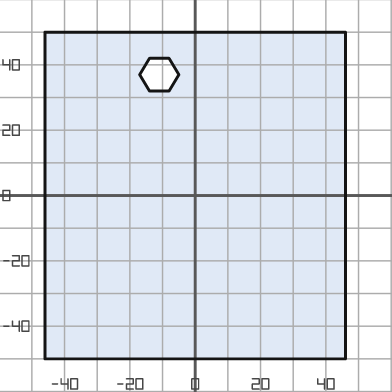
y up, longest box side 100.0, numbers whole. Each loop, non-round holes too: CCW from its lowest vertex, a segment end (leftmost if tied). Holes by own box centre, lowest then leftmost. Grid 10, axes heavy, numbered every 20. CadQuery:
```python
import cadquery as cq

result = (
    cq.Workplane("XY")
    .moveTo(-46.0, -50.0)
    .lineTo(46.0, -50.0)
    .lineTo(46.0, 50.0)
    .lineTo(-46.0, 50.0)
    .close()
    .moveTo(-14.0, 32.0)
    .lineTo(-8.0, 32.0)
    .lineTo(-5.0, 37.0)
    .lineTo(-8.0, 42.0)
    .lineTo(-14.0, 42.0)
    .lineTo(-17.0, 37.0)
    .close()
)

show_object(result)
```